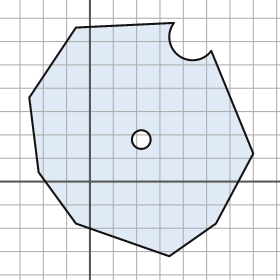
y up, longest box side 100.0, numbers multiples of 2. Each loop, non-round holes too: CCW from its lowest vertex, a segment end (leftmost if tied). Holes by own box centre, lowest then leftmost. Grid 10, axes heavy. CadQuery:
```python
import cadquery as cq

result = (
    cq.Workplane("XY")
    .moveTo(34.0, -32.0)
    .lineTo(54.0, -18.0)
    .lineTo(70.0, 12.0)
    .lineTo(52.0, 56.0)
    .threePointArc((38.0, 54.0), (36.0, 68.0))
    .lineTo(-6.0, 66.0)
    .lineTo(-26.0, 36.0)
    .lineTo(-22.0, 4.0)
    .lineTo(-6.0, -18.0)
    .close()
    .moveTo(22.0, 18.0)
    .circle(4.0)
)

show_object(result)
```